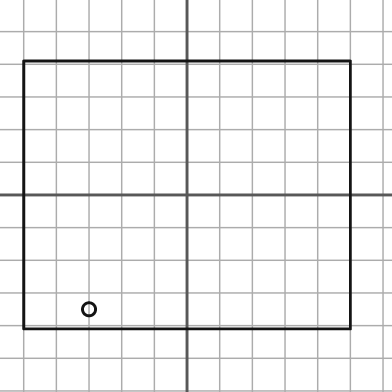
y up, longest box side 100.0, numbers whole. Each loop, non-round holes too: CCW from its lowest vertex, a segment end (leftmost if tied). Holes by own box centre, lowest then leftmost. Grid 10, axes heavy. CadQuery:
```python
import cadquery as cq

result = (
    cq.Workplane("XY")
    .moveTo(-50.0, -41.0)
    .lineTo(50.0, -41.0)
    .lineTo(50.0, 41.0)
    .lineTo(-50.0, 41.0)
    .close()
    .moveTo(-30.0, -35.0)
    .circle(2.0)
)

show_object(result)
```